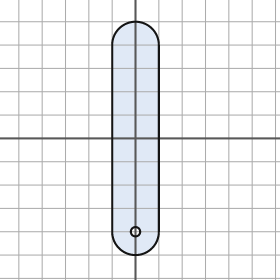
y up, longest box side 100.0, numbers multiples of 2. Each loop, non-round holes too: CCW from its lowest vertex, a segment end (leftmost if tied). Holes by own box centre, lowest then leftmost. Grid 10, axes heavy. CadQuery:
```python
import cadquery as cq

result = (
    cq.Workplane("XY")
    .moveTo(-10.0, -40.0)
    .threePointArc((0.0, -50.0), (10.0, -40.0))
    .lineTo(10.0, 40.0)
    .threePointArc((0.0, 50.0), (-10.0, 40.0))
    .close()
    .moveTo(0.0, -40.0)
    .circle(2.0)
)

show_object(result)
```